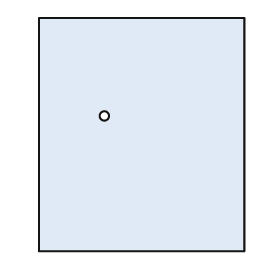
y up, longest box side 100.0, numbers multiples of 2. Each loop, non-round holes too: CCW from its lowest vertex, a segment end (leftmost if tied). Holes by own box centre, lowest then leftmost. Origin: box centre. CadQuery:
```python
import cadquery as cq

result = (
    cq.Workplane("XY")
    .moveTo(-44.0, -50.0)
    .lineTo(44.0, -50.0)
    .lineTo(44.0, 50.0)
    .lineTo(-44.0, 50.0)
    .close()
    .moveTo(-16.0, 8.0)
    .circle(2.0)
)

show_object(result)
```